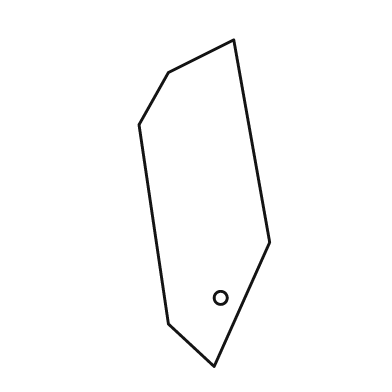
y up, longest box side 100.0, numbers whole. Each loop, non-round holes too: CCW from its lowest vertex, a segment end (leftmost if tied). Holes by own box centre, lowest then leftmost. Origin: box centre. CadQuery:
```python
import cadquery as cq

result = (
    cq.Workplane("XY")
    .moveTo(3.0, -50.0)
    .lineTo(20.0, -12.0)
    .lineTo(9.0, 50.0)
    .lineTo(-11.0, 40.0)
    .lineTo(-20.0, 24.0)
    .lineTo(-11.0, -37.0)
    .close()
    .moveTo(5.0, -29.0)
    .circle(2.0)
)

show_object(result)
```